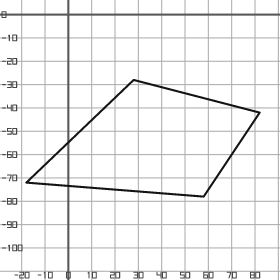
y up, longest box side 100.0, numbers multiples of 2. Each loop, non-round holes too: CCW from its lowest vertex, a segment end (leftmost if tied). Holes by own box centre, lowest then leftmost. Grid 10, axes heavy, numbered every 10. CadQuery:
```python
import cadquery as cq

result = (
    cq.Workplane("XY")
    .moveTo(58.0, -78.0)
    .lineTo(82.0, -42.0)
    .lineTo(28.0, -28.0)
    .lineTo(-18.0, -72.0)
    .close()
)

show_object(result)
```